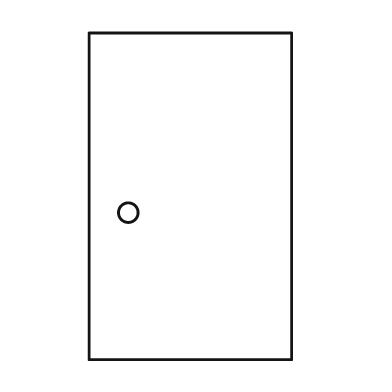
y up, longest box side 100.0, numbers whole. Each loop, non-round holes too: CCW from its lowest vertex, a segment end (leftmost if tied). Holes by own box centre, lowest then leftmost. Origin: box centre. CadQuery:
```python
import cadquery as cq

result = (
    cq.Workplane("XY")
    .moveTo(-31.0, -50.0)
    .lineTo(31.0, -50.0)
    .lineTo(31.0, 50.0)
    .lineTo(-31.0, 50.0)
    .close()
    .moveTo(-19.0, -5.0)
    .circle(3.0)
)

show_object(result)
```